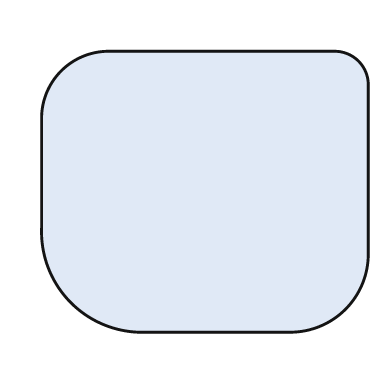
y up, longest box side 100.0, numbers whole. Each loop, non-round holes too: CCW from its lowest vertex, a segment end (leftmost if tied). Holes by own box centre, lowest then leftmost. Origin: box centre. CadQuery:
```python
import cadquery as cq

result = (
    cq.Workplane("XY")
    .moveTo(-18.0, -43.0)
    .lineTo(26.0, -43.0)
    .threePointArc((43.0, -36.0), (50.0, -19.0))
    .lineTo(50.0, 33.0)
    .threePointArc((47.0, 40.0), (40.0, 43.0))
    .lineTo(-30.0, 43.0)
    .threePointArc((-44.0, 37.0), (-50.0, 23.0))
    .lineTo(-50.0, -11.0)
    .threePointArc((-41.0, -34.0), (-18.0, -43.0))
    .close()
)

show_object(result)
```